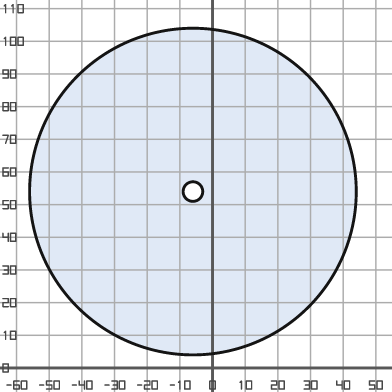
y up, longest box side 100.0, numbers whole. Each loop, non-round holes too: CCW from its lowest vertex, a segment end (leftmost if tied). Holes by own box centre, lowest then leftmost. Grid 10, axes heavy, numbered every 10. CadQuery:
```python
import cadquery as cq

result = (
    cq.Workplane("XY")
    .moveTo(-6.0, 54.0)
    .circle(50.0)
    .moveTo(-6.0, 54.0)
    .circle(3.0)
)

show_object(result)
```